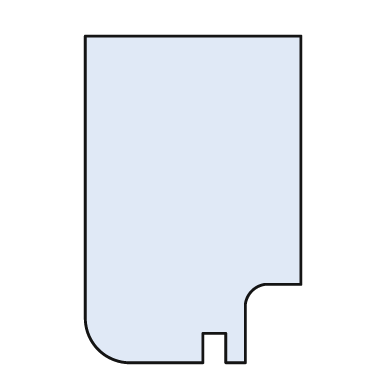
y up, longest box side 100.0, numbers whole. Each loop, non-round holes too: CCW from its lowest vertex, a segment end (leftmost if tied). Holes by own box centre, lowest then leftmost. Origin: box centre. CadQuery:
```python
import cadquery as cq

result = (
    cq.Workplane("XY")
    .moveTo(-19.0, -50.0)
    .lineTo(3.0, -50.0)
    .lineTo(3.0, -41.0)
    .lineTo(10.0, -41.0)
    .lineTo(10.0, -50.0)
    .lineTo(16.0, -50.0)
    .lineTo(16.0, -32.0)
    .threePointArc((18.0, -28.0), (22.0, -26.0))
    .lineTo(33.0, -26.0)
    .lineTo(33.0, 50.0)
    .lineTo(-33.0, 50.0)
    .lineTo(-33.0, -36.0)
    .threePointArc((-29.0, -46.0), (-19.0, -50.0))
    .close()
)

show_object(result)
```